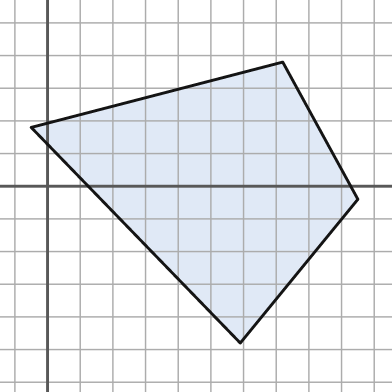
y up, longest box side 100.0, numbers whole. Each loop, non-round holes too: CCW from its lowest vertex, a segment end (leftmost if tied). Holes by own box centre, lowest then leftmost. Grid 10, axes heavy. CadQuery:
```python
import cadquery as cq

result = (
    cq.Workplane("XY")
    .moveTo(59.0, -48.0)
    .lineTo(95.0, -4.0)
    .lineTo(72.0, 38.0)
    .lineTo(-5.0, 18.0)
    .close()
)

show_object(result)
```